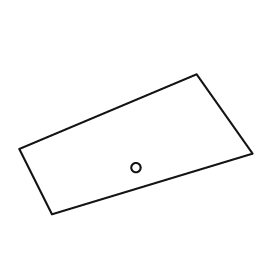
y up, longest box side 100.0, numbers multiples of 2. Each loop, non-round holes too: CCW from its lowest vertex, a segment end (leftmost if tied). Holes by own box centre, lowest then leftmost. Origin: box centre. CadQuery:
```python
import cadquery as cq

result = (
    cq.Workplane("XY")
    .moveTo(-36.0, -30.0)
    .lineTo(50.0, -4.0)
    .lineTo(26.0, 30.0)
    .lineTo(-50.0, -2.0)
    .close()
    .moveTo(0.0, -10.0)
    .circle(2.0)
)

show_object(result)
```